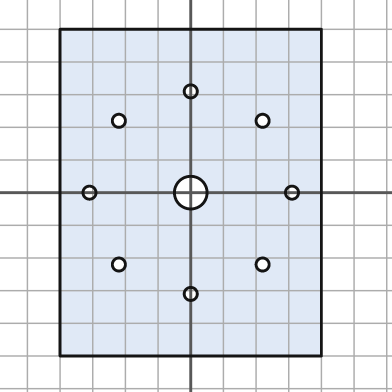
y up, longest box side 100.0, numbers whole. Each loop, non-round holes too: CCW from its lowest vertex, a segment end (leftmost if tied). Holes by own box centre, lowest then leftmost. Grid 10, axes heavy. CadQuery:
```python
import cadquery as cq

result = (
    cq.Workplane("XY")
    .moveTo(-40.0, -50.0)
    .lineTo(40.0, -50.0)
    .lineTo(40.0, 50.0)
    .lineTo(-40.0, 50.0)
    .close()
    .moveTo(0.0, -31.0)
    .circle(2.0)
    .moveTo(-22.0, -22.0)
    .circle(2.0)
    .moveTo(22.0, -22.0)
    .circle(2.0)
    .moveTo(-31.0, 0.0)
    .circle(2.0)
    .moveTo(0.0, 0.0)
    .circle(5.0)
    .moveTo(31.0, 0.0)
    .circle(2.0)
    .moveTo(-22.0, 22.0)
    .circle(2.0)
    .moveTo(22.0, 22.0)
    .circle(2.0)
    .moveTo(0.0, 31.0)
    .circle(2.0)
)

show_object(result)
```